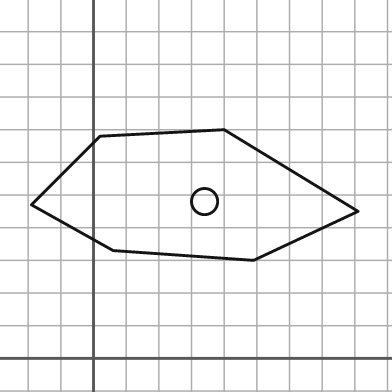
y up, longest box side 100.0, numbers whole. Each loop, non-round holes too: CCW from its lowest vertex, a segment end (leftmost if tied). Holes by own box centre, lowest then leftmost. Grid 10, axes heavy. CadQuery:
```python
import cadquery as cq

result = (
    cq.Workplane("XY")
    .moveTo(49.0, 30.0)
    .lineTo(81.0, 45.0)
    .lineTo(40.0, 70.0)
    .lineTo(2.0, 68.0)
    .lineTo(-19.0, 47.0)
    .lineTo(6.0, 33.0)
    .close()
    .moveTo(34.0, 48.0)
    .circle(4.0)
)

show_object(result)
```